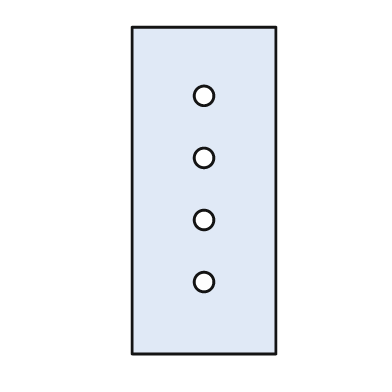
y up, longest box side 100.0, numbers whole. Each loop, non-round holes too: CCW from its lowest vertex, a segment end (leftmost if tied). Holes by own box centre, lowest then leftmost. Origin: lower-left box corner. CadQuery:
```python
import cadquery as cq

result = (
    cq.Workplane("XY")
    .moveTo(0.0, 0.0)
    .lineTo(44.0, 0.0)
    .lineTo(44.0, 100.0)
    .lineTo(0.0, 100.0)
    .close()
    .moveTo(22.0, 22.0)
    .circle(3.0)
    .moveTo(22.0, 41.0)
    .circle(3.0)
    .moveTo(22.0, 60.0)
    .circle(3.0)
    .moveTo(22.0, 79.0)
    .circle(3.0)
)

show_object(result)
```